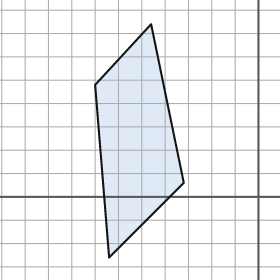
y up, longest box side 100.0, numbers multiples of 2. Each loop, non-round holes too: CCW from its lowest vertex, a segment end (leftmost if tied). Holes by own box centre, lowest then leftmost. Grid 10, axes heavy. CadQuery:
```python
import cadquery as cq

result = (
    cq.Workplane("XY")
    .moveTo(-64.0, -26.0)
    .lineTo(-32.0, 6.0)
    .lineTo(-46.0, 74.0)
    .lineTo(-70.0, 48.0)
    .close()
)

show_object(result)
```